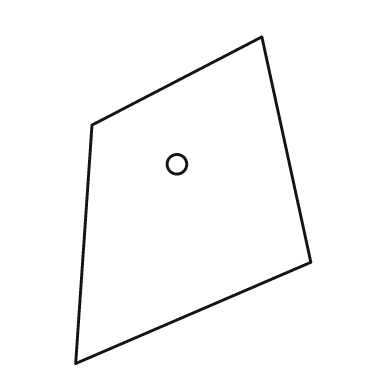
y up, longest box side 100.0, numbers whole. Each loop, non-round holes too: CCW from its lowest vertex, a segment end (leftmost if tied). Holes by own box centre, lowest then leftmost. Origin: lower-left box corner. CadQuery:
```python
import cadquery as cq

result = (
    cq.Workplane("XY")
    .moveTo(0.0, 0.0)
    .lineTo(72.0, 31.0)
    .lineTo(57.0, 100.0)
    .lineTo(5.0, 73.0)
    .close()
    .moveTo(31.0, 61.0)
    .circle(3.0)
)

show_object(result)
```